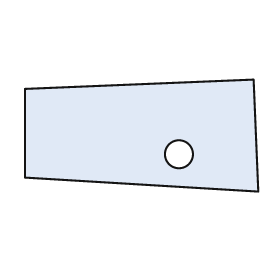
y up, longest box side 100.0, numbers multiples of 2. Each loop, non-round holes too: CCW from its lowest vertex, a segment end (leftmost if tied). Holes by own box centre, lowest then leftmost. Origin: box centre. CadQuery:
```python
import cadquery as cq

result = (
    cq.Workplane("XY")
    .moveTo(50.0, -24.0)
    .lineTo(48.0, 24.0)
    .lineTo(-50.0, 20.0)
    .lineTo(-50.0, -18.0)
    .close()
    .moveTo(16.0, -8.0)
    .circle(6.0)
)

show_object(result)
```